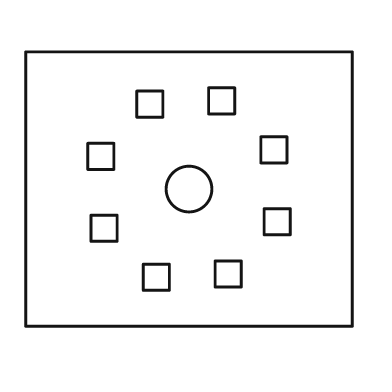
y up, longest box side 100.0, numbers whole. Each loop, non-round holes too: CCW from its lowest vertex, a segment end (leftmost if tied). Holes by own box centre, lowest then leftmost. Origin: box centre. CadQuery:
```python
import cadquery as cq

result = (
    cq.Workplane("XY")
    .moveTo(-50.0, -42.0)
    .lineTo(50.0, -42.0)
    .lineTo(50.0, 42.0)
    .lineTo(-50.0, 42.0)
    .close()
    .moveTo(-14.0, -31.0)
    .lineTo(-6.0, -31.0)
    .lineTo(-6.0, -23.0)
    .lineTo(-14.0, -23.0)
    .close()
    .moveTo(8.0, -30.0)
    .lineTo(16.0, -30.0)
    .lineTo(16.0, -22.0)
    .lineTo(8.0, -22.0)
    .close()
    .moveTo(-30.0, -16.0)
    .lineTo(-22.0, -16.0)
    .lineTo(-22.0, -8.0)
    .lineTo(-30.0, -8.0)
    .close()
    .moveTo(23.0, -14.0)
    .lineTo(31.0, -14.0)
    .lineTo(31.0, -6.0)
    .lineTo(23.0, -6.0)
    .close()
    .moveTo(0.0, 0.0)
    .circle(7.0)
    .moveTo(-31.0, 6.0)
    .lineTo(-23.0, 6.0)
    .lineTo(-23.0, 14.0)
    .lineTo(-31.0, 14.0)
    .close()
    .moveTo(22.0, 8.0)
    .lineTo(30.0, 8.0)
    .lineTo(30.0, 16.0)
    .lineTo(22.0, 16.0)
    .close()
    .moveTo(-16.0, 22.0)
    .lineTo(-8.0, 22.0)
    .lineTo(-8.0, 30.0)
    .lineTo(-16.0, 30.0)
    .close()
    .moveTo(6.0, 23.0)
    .lineTo(14.0, 23.0)
    .lineTo(14.0, 31.0)
    .lineTo(6.0, 31.0)
    .close()
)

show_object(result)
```